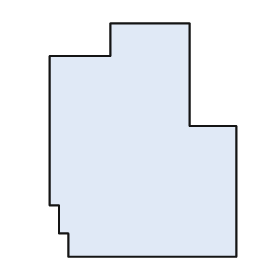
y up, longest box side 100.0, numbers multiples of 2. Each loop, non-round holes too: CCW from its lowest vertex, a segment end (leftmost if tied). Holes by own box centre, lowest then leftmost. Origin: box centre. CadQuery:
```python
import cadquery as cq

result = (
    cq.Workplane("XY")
    .moveTo(-32.0, -50.0)
    .lineTo(40.0, -50.0)
    .lineTo(40.0, 6.0)
    .lineTo(20.0, 6.0)
    .lineTo(20.0, 50.0)
    .lineTo(-14.0, 50.0)
    .lineTo(-14.0, 36.0)
    .lineTo(-40.0, 36.0)
    .lineTo(-40.0, -28.0)
    .lineTo(-36.0, -28.0)
    .lineTo(-36.0, -40.0)
    .lineTo(-32.0, -40.0)
    .close()
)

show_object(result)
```